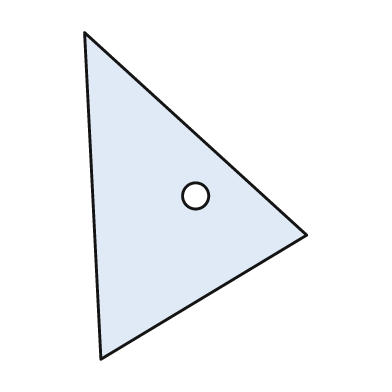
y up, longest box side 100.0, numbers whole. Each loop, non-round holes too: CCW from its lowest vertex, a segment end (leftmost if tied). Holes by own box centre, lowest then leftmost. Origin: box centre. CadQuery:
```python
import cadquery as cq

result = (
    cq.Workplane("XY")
    .moveTo(-29.0, -50.0)
    .lineTo(34.0, -12.0)
    .lineTo(-34.0, 50.0)
    .close()
    .moveTo(0.0, 0.0)
    .circle(4.0)
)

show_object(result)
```